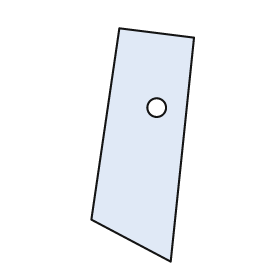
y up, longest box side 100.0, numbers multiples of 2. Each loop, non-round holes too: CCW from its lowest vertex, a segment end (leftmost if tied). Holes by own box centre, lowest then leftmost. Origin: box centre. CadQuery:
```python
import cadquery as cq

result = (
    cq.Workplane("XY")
    .moveTo(12.0, -50.0)
    .lineTo(22.0, 46.0)
    .lineTo(-10.0, 50.0)
    .lineTo(-22.0, -32.0)
    .close()
    .moveTo(6.0, 16.0)
    .circle(4.0)
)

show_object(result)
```